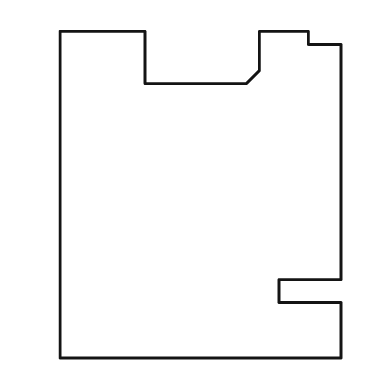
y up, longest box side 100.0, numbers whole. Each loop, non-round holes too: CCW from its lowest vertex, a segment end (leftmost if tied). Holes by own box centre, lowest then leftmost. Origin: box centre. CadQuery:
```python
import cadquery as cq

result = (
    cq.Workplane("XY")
    .moveTo(-43.0, -50.0)
    .lineTo(43.0, -50.0)
    .lineTo(43.0, -33.0)
    .lineTo(24.0, -33.0)
    .lineTo(24.0, -26.0)
    .lineTo(43.0, -26.0)
    .lineTo(43.0, 46.0)
    .lineTo(33.0, 46.0)
    .lineTo(33.0, 50.0)
    .lineTo(18.0, 50.0)
    .lineTo(18.0, 38.0)
    .lineTo(14.0, 34.0)
    .lineTo(-17.0, 34.0)
    .lineTo(-17.0, 50.0)
    .lineTo(-43.0, 50.0)
    .close()
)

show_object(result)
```